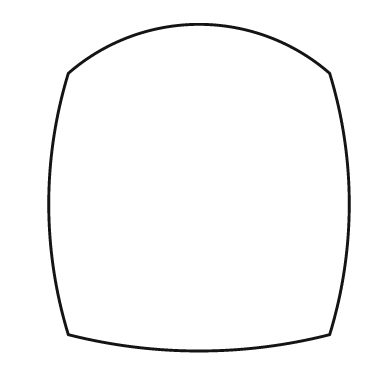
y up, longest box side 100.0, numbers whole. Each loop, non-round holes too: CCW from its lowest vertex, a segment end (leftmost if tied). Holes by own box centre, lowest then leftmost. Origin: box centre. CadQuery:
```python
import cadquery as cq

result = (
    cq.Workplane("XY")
    .moveTo(-40.0, -45.0)
    .threePointArc((0.0, -50.0), (40.0, -45.0))
    .threePointArc((46.0, -5.0), (40.0, 35.0))
    .threePointArc((0.0, 50.0), (-40.0, 35.0))
    .threePointArc((-46.0, -5.0), (-40.0, -45.0))
    .close()
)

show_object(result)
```